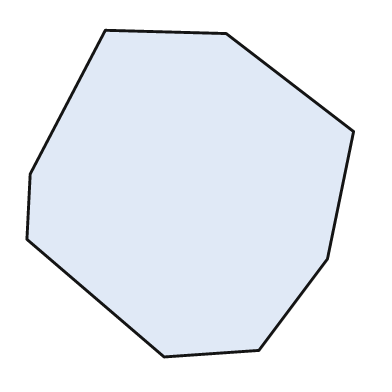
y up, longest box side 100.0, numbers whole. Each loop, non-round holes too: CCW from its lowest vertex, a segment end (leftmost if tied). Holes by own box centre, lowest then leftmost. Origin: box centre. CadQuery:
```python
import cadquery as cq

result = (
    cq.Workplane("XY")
    .moveTo(-8.0, -50.0)
    .lineTo(21.0, -48.0)
    .lineTo(42.0, -20.0)
    .lineTo(50.0, 19.0)
    .lineTo(11.0, 49.0)
    .lineTo(-26.0, 50.0)
    .lineTo(-49.0, 6.0)
    .lineTo(-50.0, -14.0)
    .close()
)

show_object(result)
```